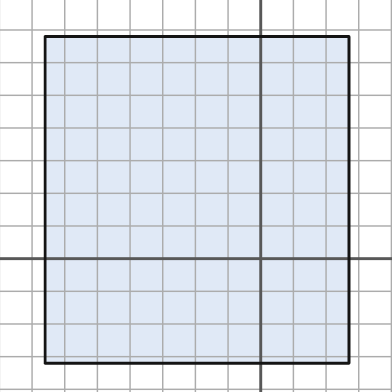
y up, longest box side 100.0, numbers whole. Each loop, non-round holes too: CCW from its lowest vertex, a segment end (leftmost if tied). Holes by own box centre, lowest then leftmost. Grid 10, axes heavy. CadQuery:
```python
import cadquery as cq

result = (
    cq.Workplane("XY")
    .moveTo(-66.0, -32.0)
    .lineTo(27.0, -32.0)
    .lineTo(27.0, 68.0)
    .lineTo(-66.0, 68.0)
    .close()
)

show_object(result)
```